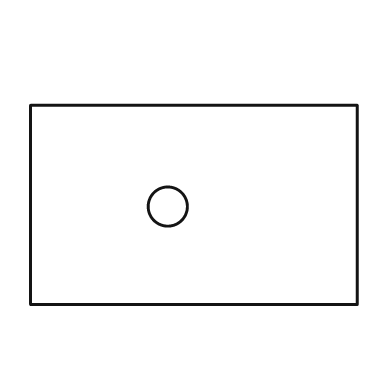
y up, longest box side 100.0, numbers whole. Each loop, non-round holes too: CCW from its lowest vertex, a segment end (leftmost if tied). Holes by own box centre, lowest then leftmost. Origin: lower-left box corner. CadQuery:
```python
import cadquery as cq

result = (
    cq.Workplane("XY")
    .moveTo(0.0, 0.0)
    .lineTo(100.0, 0.0)
    .lineTo(100.0, 61.0)
    .lineTo(0.0, 61.0)
    .close()
    .moveTo(42.0, 30.0)
    .circle(6.0)
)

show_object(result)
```